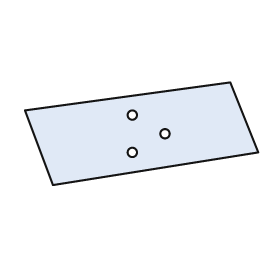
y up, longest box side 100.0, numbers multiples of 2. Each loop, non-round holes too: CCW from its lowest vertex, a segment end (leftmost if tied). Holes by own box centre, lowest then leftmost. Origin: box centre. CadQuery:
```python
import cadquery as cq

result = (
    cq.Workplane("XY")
    .moveTo(-38.0, -22.0)
    .lineTo(50.0, -8.0)
    .lineTo(38.0, 22.0)
    .lineTo(-50.0, 10.0)
    .close()
    .moveTo(-4.0, -8.0)
    .circle(2.0)
    .moveTo(10.0, 0.0)
    .circle(2.0)
    .moveTo(-4.0, 8.0)
    .circle(2.0)
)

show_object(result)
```